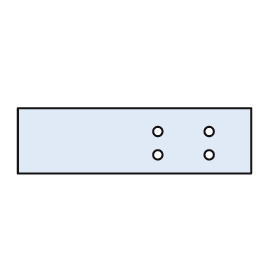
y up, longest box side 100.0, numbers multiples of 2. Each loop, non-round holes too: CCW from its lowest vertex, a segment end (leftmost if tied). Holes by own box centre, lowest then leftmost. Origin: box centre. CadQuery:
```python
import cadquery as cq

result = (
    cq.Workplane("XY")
    .moveTo(-50.0, -14.0)
    .lineTo(50.0, -14.0)
    .lineTo(50.0, 14.0)
    .lineTo(-50.0, 14.0)
    .close()
    .moveTo(10.0, -6.0)
    .circle(2.0)
    .moveTo(32.0, -6.0)
    .circle(2.0)
    .moveTo(10.0, 4.0)
    .circle(2.0)
    .moveTo(32.0, 4.0)
    .circle(2.0)
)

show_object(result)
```